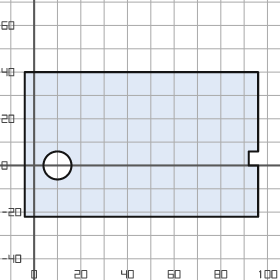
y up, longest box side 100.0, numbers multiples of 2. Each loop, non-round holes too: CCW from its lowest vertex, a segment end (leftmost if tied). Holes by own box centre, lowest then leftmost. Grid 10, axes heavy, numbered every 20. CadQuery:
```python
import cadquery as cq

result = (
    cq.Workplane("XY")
    .moveTo(-4.0, -22.0)
    .lineTo(96.0, -22.0)
    .lineTo(96.0, 0.0)
    .lineTo(92.0, 0.0)
    .lineTo(92.0, 6.0)
    .lineTo(96.0, 6.0)
    .lineTo(96.0, 40.0)
    .lineTo(-4.0, 40.0)
    .close()
    .moveTo(10.0, 0.0)
    .circle(6.0)
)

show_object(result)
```